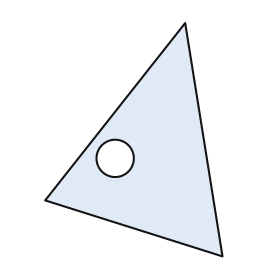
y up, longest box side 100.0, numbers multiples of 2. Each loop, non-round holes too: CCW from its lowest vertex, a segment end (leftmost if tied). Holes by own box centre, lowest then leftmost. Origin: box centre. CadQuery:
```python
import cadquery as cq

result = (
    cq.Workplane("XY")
    .moveTo(38.0, -50.0)
    .lineTo(22.0, 50.0)
    .lineTo(-38.0, -26.0)
    .close()
    .moveTo(-8.0, -8.0)
    .circle(8.0)
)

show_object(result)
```